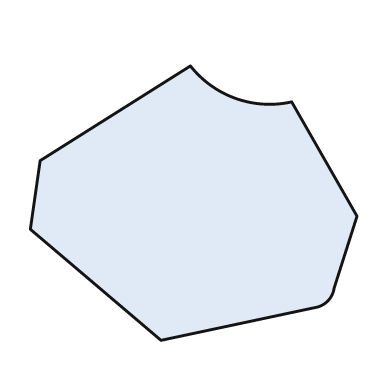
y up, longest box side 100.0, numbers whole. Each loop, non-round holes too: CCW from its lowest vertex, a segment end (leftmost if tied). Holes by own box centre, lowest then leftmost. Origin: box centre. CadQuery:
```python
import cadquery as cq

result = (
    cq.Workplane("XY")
    .moveTo(-10.0, -42.0)
    .lineTo(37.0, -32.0)
    .threePointArc((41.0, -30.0), (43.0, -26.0))
    .lineTo(50.0, -4.0)
    .lineTo(30.0, 31.0)
    .threePointArc((13.0, 32.0), (-1.0, 42.0))
    .lineTo(-47.0, 13.0)
    .lineTo(-50.0, -8.0)
    .close()
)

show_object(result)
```